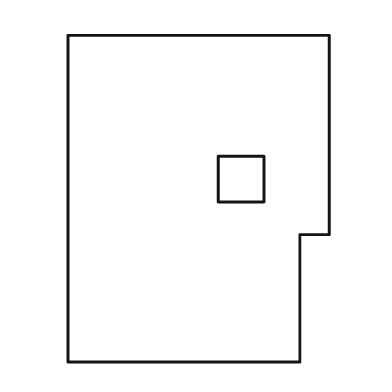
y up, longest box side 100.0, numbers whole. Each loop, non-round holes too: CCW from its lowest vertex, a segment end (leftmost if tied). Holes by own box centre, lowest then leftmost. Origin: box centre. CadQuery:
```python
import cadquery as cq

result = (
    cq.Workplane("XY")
    .moveTo(-40.0, -50.0)
    .lineTo(31.0, -50.0)
    .lineTo(31.0, -11.0)
    .lineTo(40.0, -11.0)
    .lineTo(40.0, 50.0)
    .lineTo(-40.0, 50.0)
    .close()
    .moveTo(6.0, -1.0)
    .lineTo(20.0, -1.0)
    .lineTo(20.0, 13.0)
    .lineTo(6.0, 13.0)
    .close()
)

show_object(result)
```